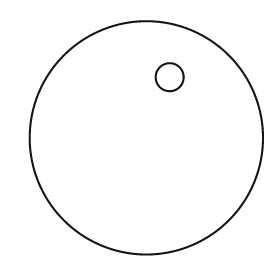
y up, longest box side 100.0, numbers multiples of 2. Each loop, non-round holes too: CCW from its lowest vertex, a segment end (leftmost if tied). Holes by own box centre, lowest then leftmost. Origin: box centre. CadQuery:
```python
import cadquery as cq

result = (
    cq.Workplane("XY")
    .moveTo(0.0, 0.0)
    .circle(50.0)
    .moveTo(10.0, 26.0)
    .circle(6.0)
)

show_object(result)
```